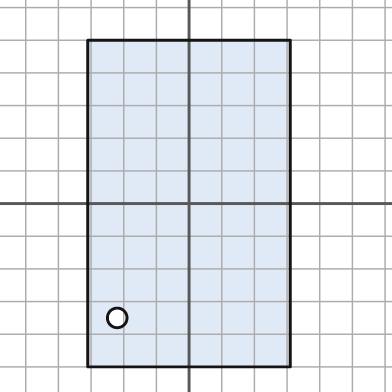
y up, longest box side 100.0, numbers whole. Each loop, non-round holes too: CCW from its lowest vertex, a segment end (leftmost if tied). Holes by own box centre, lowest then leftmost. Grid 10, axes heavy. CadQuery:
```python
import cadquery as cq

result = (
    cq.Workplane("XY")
    .moveTo(-31.0, -50.0)
    .lineTo(31.0, -50.0)
    .lineTo(31.0, 50.0)
    .lineTo(-31.0, 50.0)
    .close()
    .moveTo(-22.0, -35.0)
    .circle(3.0)
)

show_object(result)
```